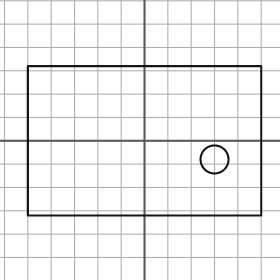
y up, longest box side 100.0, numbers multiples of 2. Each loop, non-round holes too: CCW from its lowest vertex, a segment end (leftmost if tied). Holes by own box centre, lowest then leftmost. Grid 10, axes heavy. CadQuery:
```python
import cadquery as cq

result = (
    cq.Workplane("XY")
    .moveTo(-50.0, -32.0)
    .lineTo(50.0, -32.0)
    .lineTo(50.0, 32.0)
    .lineTo(-50.0, 32.0)
    .close()
    .moveTo(30.0, -8.0)
    .circle(6.0)
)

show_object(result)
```